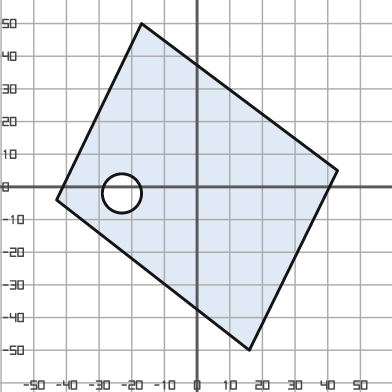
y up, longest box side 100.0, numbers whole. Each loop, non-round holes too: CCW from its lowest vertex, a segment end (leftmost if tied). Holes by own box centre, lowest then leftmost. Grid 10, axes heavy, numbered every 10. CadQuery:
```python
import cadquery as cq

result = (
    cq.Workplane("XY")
    .moveTo(16.0, -50.0)
    .lineTo(43.0, 5.0)
    .lineTo(-17.0, 50.0)
    .lineTo(-43.0, -4.0)
    .close()
    .moveTo(-23.0, -2.0)
    .circle(6.0)
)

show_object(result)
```